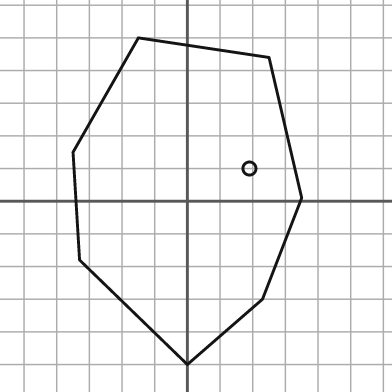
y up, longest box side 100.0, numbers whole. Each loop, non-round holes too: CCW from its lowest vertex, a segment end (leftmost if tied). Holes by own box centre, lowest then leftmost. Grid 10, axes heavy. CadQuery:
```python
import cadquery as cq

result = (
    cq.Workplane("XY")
    .moveTo(0.0, -50.0)
    .lineTo(23.0, -30.0)
    .lineTo(35.0, 1.0)
    .lineTo(25.0, 44.0)
    .lineTo(-15.0, 50.0)
    .lineTo(-35.0, 15.0)
    .lineTo(-33.0, -18.0)
    .close()
    .moveTo(19.0, 10.0)
    .circle(2.0)
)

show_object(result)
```